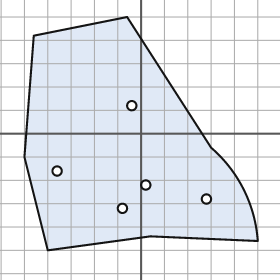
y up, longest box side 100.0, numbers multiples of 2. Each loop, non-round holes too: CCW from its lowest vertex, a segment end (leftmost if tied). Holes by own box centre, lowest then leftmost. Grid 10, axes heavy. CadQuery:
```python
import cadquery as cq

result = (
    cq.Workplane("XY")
    .moveTo(-40.0, -50.0)
    .lineTo(4.0, -44.0)
    .lineTo(50.0, -46.0)
    .threePointArc((44.0, -24.0), (30.0, -6.0))
    .lineTo(-6.0, 50.0)
    .lineTo(-46.0, 42.0)
    .lineTo(-50.0, -10.0)
    .close()
    .moveTo(-8.0, -32.0)
    .circle(2.0)
    .moveTo(28.0, -28.0)
    .circle(2.0)
    .moveTo(2.0, -22.0)
    .circle(2.0)
    .moveTo(-36.0, -16.0)
    .circle(2.0)
    .moveTo(-4.0, 12.0)
    .circle(2.0)
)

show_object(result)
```